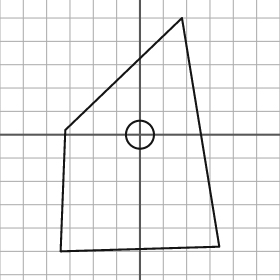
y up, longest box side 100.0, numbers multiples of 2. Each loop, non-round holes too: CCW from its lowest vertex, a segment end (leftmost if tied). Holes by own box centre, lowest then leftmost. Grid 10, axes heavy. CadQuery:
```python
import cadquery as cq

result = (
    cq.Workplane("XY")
    .moveTo(-34.0, -50.0)
    .lineTo(34.0, -48.0)
    .lineTo(18.0, 50.0)
    .lineTo(-32.0, 2.0)
    .close()
    .moveTo(0.0, 0.0)
    .circle(6.0)
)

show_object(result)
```